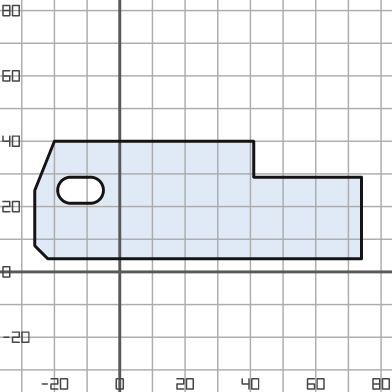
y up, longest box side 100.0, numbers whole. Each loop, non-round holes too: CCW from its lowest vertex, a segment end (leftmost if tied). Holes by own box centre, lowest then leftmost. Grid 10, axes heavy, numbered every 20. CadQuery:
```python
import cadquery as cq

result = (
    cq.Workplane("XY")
    .moveTo(-22.0, 4.0)
    .lineTo(74.0, 4.0)
    .lineTo(74.0, 29.0)
    .lineTo(41.0, 29.0)
    .lineTo(41.0, 40.0)
    .lineTo(-20.0, 40.0)
    .lineTo(-26.0, 25.0)
    .lineTo(-26.0, 8.0)
    .close()
    .moveTo(-15.0, 21.0)
    .lineTo(-9.0, 21.0)
    .threePointArc((-5.0, 25.0), (-9.0, 29.0))
    .lineTo(-15.0, 29.0)
    .threePointArc((-19.0, 25.0), (-15.0, 21.0))
    .close()
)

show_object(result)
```